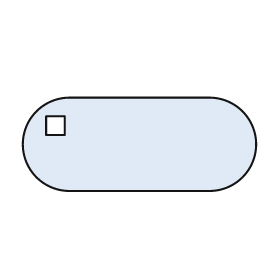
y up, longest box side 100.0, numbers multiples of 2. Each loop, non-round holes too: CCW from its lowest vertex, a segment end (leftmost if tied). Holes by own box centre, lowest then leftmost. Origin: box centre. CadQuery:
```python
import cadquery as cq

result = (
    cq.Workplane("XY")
    .moveTo(-30.0, -20.0)
    .lineTo(30.0, -20.0)
    .threePointArc((50.0, 0.0), (30.0, 20.0))
    .lineTo(-30.0, 20.0)
    .threePointArc((-50.0, 0.0), (-30.0, -20.0))
    .close()
    .moveTo(-40.0, 4.0)
    .lineTo(-32.0, 4.0)
    .lineTo(-32.0, 12.0)
    .lineTo(-40.0, 12.0)
    .close()
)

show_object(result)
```